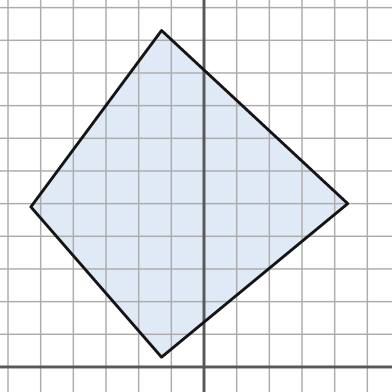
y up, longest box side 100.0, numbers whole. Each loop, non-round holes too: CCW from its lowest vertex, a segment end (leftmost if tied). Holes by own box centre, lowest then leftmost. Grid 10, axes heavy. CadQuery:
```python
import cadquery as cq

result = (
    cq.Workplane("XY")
    .moveTo(-13.0, 3.0)
    .lineTo(44.0, 50.0)
    .lineTo(-13.0, 103.0)
    .lineTo(-53.0, 49.0)
    .close()
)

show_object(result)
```